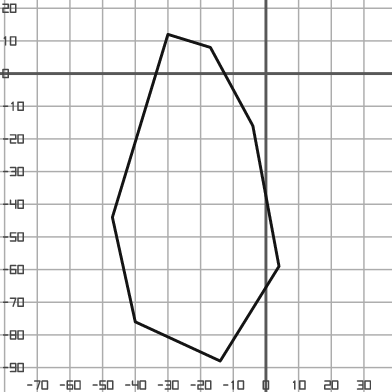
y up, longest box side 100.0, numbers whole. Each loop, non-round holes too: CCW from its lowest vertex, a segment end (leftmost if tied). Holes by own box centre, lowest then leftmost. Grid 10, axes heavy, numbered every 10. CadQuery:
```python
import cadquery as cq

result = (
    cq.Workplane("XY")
    .moveTo(-14.0, -88.0)
    .lineTo(4.0, -59.0)
    .lineTo(-4.0, -16.0)
    .lineTo(-17.0, 8.0)
    .lineTo(-30.0, 12.0)
    .lineTo(-47.0, -44.0)
    .lineTo(-40.0, -76.0)
    .close()
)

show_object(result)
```